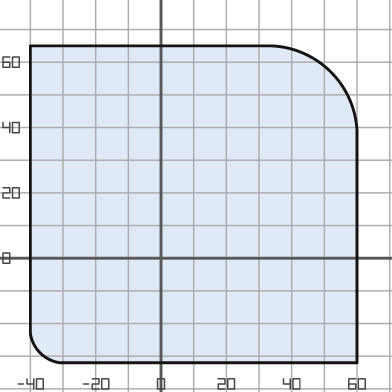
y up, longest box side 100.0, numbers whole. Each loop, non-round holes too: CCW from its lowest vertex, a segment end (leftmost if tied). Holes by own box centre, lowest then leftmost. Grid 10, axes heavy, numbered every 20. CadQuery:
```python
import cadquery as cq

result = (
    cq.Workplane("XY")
    .moveTo(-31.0, -32.0)
    .lineTo(60.0, -32.0)
    .lineTo(60.0, 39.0)
    .threePointArc((52.0, 57.0), (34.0, 65.0))
    .lineTo(-40.0, 65.0)
    .lineTo(-40.0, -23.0)
    .threePointArc((-37.0, -29.0), (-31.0, -32.0))
    .close()
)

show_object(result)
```